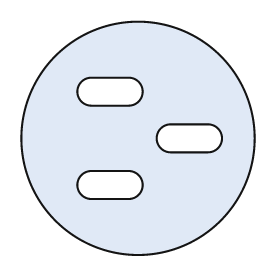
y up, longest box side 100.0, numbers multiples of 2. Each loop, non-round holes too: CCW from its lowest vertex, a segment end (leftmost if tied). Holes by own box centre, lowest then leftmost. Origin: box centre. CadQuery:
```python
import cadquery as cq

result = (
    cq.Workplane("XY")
    .moveTo(0.0, 0.0)
    .circle(50.0)
    .moveTo(-20.0, -26.0)
    .lineTo(-4.0, -26.0)
    .threePointArc((2.0, -20.0), (-4.0, -14.0))
    .lineTo(-20.0, -14.0)
    .threePointArc((-26.0, -20.0), (-20.0, -26.0))
    .close()
    .moveTo(14.0, -6.0)
    .lineTo(30.0, -6.0)
    .threePointArc((36.0, 0.0), (30.0, 6.0))
    .lineTo(14.0, 6.0)
    .threePointArc((8.0, 0.0), (14.0, -6.0))
    .close()
    .moveTo(-20.0, 14.0)
    .lineTo(-4.0, 14.0)
    .threePointArc((2.0, 20.0), (-4.0, 26.0))
    .lineTo(-20.0, 26.0)
    .threePointArc((-26.0, 20.0), (-20.0, 14.0))
    .close()
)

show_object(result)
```